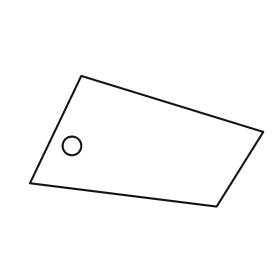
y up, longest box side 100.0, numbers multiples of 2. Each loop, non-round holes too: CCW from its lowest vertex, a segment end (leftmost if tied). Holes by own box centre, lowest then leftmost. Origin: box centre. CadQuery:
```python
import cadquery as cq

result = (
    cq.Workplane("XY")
    .moveTo(30.0, -28.0)
    .lineTo(50.0, 4.0)
    .lineTo(-28.0, 28.0)
    .lineTo(-50.0, -18.0)
    .close()
    .moveTo(-32.0, -2.0)
    .circle(4.0)
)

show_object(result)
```